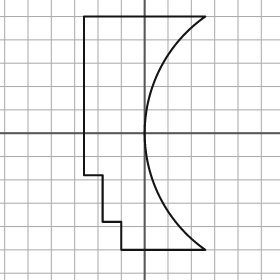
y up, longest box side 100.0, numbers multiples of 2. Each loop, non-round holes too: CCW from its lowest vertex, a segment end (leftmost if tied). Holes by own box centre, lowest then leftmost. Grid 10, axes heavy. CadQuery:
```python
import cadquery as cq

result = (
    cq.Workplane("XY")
    .moveTo(-10.0, -50.0)
    .lineTo(26.0, -50.0)
    .threePointArc((0.0, 0.0), (26.0, 50.0))
    .lineTo(-26.0, 50.0)
    .lineTo(-26.0, -18.0)
    .lineTo(-18.0, -18.0)
    .lineTo(-18.0, -38.0)
    .lineTo(-10.0, -38.0)
    .close()
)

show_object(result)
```